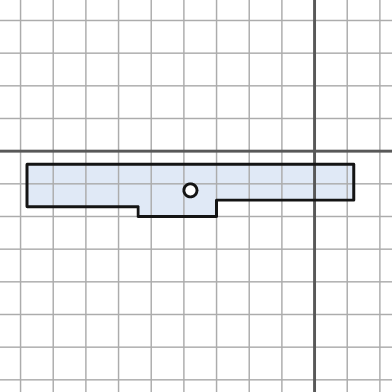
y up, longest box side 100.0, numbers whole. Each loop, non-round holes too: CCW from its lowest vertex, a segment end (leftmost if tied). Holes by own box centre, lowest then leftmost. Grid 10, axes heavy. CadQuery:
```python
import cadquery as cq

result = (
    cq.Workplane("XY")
    .moveTo(-54.0, -20.0)
    .lineTo(-30.0, -20.0)
    .lineTo(-30.0, -15.0)
    .lineTo(12.0, -15.0)
    .lineTo(12.0, -4.0)
    .lineTo(-88.0, -4.0)
    .lineTo(-88.0, -17.0)
    .lineTo(-54.0, -17.0)
    .close()
    .moveTo(-38.0, -12.0)
    .circle(2.0)
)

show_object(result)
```